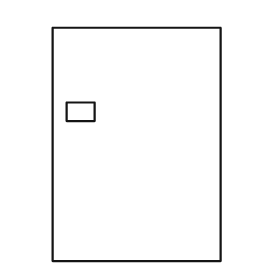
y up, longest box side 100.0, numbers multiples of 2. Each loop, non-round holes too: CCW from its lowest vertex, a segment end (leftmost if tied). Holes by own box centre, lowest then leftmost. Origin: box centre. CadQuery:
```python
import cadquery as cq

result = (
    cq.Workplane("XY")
    .moveTo(-36.0, -50.0)
    .lineTo(36.0, -50.0)
    .lineTo(36.0, 50.0)
    .lineTo(-36.0, 50.0)
    .close()
    .moveTo(-30.0, 10.0)
    .lineTo(-18.0, 10.0)
    .lineTo(-18.0, 18.0)
    .lineTo(-30.0, 18.0)
    .close()
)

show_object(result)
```